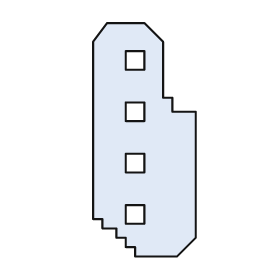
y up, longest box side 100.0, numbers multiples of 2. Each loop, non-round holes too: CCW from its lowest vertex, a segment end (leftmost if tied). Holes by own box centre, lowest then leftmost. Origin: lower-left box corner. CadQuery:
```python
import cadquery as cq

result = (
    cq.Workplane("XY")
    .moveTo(18.0, 0.0)
    .lineTo(36.0, 0.0)
    .lineTo(44.0, 8.0)
    .lineTo(44.0, 62.0)
    .lineTo(34.0, 62.0)
    .lineTo(34.0, 68.0)
    .lineTo(30.0, 68.0)
    .lineTo(30.0, 92.0)
    .lineTo(22.0, 100.0)
    .lineTo(6.0, 100.0)
    .lineTo(0.0, 92.0)
    .lineTo(0.0, 16.0)
    .lineTo(4.0, 16.0)
    .lineTo(4.0, 12.0)
    .lineTo(10.0, 12.0)
    .lineTo(10.0, 8.0)
    .lineTo(14.0, 8.0)
    .lineTo(14.0, 4.0)
    .lineTo(18.0, 4.0)
    .close()
    .moveTo(14.0, 14.0)
    .lineTo(22.0, 14.0)
    .lineTo(22.0, 22.0)
    .lineTo(14.0, 22.0)
    .close()
    .moveTo(14.0, 36.0)
    .lineTo(22.0, 36.0)
    .lineTo(22.0, 44.0)
    .lineTo(14.0, 44.0)
    .close()
    .moveTo(14.0, 58.0)
    .lineTo(22.0, 58.0)
    .lineTo(22.0, 66.0)
    .lineTo(14.0, 66.0)
    .close()
    .moveTo(14.0, 80.0)
    .lineTo(22.0, 80.0)
    .lineTo(22.0, 88.0)
    .lineTo(14.0, 88.0)
    .close()
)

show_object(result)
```